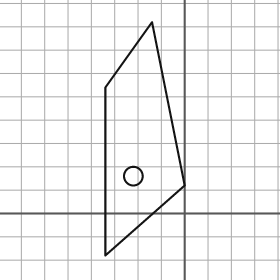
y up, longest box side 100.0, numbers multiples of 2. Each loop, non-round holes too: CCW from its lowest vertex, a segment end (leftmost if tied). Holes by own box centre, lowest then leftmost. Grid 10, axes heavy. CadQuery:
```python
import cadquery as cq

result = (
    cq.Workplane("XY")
    .moveTo(-34.0, -18.0)
    .lineTo(0.0, 12.0)
    .lineTo(-14.0, 82.0)
    .lineTo(-34.0, 54.0)
    .close()
    .moveTo(-22.0, 16.0)
    .circle(4.0)
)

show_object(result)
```